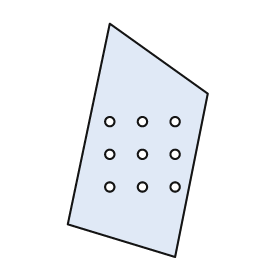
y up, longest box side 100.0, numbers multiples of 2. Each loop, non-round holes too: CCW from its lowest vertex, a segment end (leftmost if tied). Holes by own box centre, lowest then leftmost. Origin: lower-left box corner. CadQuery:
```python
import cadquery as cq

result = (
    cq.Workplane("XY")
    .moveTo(46.0, 0.0)
    .lineTo(60.0, 70.0)
    .lineTo(18.0, 100.0)
    .lineTo(0.0, 14.0)
    .close()
    .moveTo(18.0, 30.0)
    .circle(2.0)
    .moveTo(32.0, 30.0)
    .circle(2.0)
    .moveTo(46.0, 30.0)
    .circle(2.0)
    .moveTo(18.0, 44.0)
    .circle(2.0)
    .moveTo(32.0, 44.0)
    .circle(2.0)
    .moveTo(46.0, 44.0)
    .circle(2.0)
    .moveTo(18.0, 58.0)
    .circle(2.0)
    .moveTo(32.0, 58.0)
    .circle(2.0)
    .moveTo(46.0, 58.0)
    .circle(2.0)
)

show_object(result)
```